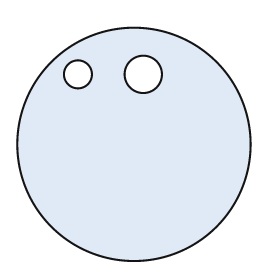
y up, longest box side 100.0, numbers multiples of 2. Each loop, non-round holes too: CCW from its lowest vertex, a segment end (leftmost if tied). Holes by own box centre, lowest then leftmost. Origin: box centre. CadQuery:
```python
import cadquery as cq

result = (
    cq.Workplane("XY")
    .moveTo(0.0, 0.0)
    .circle(50.0)
    .moveTo(-24.0, 30.0)
    .circle(6.0)
    .moveTo(4.0, 30.0)
    .circle(8.0)
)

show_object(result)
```